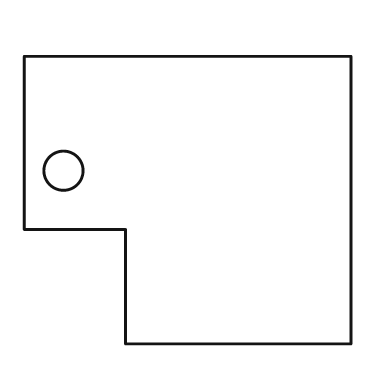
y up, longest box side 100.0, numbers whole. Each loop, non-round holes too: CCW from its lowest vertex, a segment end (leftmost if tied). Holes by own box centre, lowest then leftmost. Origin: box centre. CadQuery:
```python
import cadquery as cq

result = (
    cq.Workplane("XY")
    .moveTo(-19.0, -44.0)
    .lineTo(50.0, -44.0)
    .lineTo(50.0, 44.0)
    .lineTo(-50.0, 44.0)
    .lineTo(-50.0, -9.0)
    .lineTo(-19.0, -9.0)
    .close()
    .moveTo(-38.0, 9.0)
    .circle(6.0)
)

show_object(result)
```